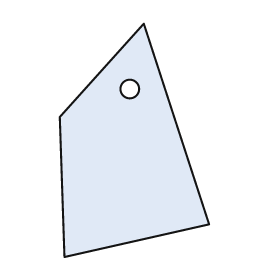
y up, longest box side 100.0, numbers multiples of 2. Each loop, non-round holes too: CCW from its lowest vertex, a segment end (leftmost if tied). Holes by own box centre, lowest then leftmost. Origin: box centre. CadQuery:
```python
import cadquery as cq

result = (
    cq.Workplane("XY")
    .moveTo(-30.0, -50.0)
    .lineTo(32.0, -36.0)
    .lineTo(4.0, 50.0)
    .lineTo(-32.0, 10.0)
    .close()
    .moveTo(-2.0, 22.0)
    .circle(4.0)
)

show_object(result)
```